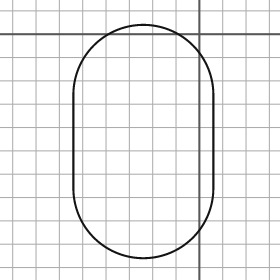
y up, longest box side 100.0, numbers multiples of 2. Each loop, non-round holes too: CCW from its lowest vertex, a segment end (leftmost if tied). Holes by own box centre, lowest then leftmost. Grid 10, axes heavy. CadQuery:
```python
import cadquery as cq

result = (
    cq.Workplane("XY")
    .moveTo(-54.0, -66.0)
    .threePointArc((-24.0, -96.0), (6.0, -66.0))
    .lineTo(6.0, -26.0)
    .threePointArc((-24.0, 4.0), (-54.0, -26.0))
    .close()
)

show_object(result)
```